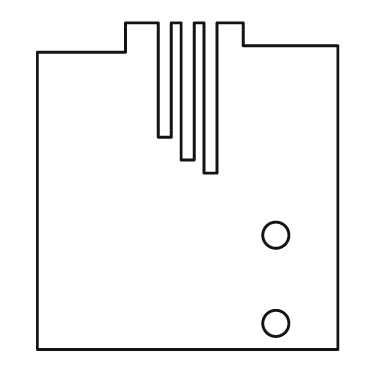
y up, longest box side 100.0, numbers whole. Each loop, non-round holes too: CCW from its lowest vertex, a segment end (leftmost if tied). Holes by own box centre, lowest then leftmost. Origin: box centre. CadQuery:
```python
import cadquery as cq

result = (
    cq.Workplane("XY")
    .moveTo(-46.0, -50.0)
    .lineTo(46.0, -50.0)
    .lineTo(46.0, 43.0)
    .lineTo(17.0, 43.0)
    .lineTo(17.0, 50.0)
    .lineTo(9.0, 50.0)
    .lineTo(9.0, 4.0)
    .lineTo(5.0, 4.0)
    .lineTo(5.0, 50.0)
    .lineTo(2.0, 50.0)
    .lineTo(2.0, 8.0)
    .lineTo(-2.0, 8.0)
    .lineTo(-2.0, 50.0)
    .lineTo(-5.0, 50.0)
    .lineTo(-5.0, 15.0)
    .lineTo(-9.0, 15.0)
    .lineTo(-9.0, 50.0)
    .lineTo(-19.0, 50.0)
    .lineTo(-19.0, 41.0)
    .lineTo(-46.0, 41.0)
    .close()
    .moveTo(27.0, -42.0)
    .circle(4.0)
    .moveTo(27.0, -15.0)
    .circle(4.0)
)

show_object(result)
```